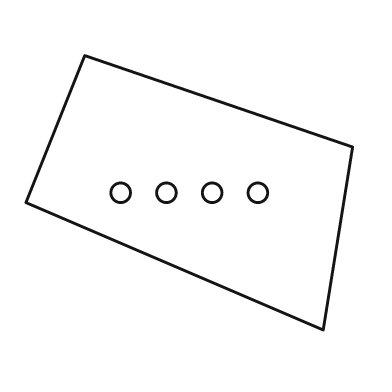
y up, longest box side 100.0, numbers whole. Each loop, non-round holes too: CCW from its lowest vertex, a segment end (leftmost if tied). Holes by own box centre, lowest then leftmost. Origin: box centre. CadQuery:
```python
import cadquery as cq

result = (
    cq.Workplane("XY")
    .moveTo(41.0, -42.0)
    .lineTo(50.0, 14.0)
    .lineTo(-32.0, 42.0)
    .lineTo(-50.0, -3.0)
    .close()
    .moveTo(-21.0, 0.0)
    .circle(3.0)
    .moveTo(-7.0, 0.0)
    .circle(3.0)
    .moveTo(7.0, 0.0)
    .circle(3.0)
    .moveTo(21.0, 0.0)
    .circle(3.0)
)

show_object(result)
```